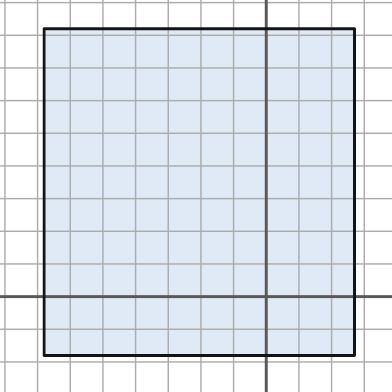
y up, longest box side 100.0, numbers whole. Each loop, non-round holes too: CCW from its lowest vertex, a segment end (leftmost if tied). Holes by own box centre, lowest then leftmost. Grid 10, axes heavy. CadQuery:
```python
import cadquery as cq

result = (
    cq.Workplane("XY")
    .moveTo(-68.0, -18.0)
    .lineTo(27.0, -18.0)
    .lineTo(27.0, 82.0)
    .lineTo(-68.0, 82.0)
    .close()
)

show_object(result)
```